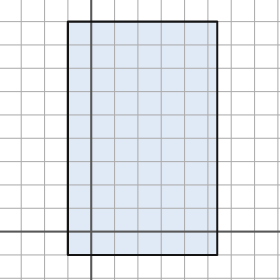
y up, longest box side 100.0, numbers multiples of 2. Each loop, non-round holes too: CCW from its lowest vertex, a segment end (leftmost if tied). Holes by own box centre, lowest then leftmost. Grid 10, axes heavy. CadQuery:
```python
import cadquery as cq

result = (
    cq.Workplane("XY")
    .moveTo(-10.0, -10.0)
    .lineTo(54.0, -10.0)
    .lineTo(54.0, 90.0)
    .lineTo(-10.0, 90.0)
    .close()
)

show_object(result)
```